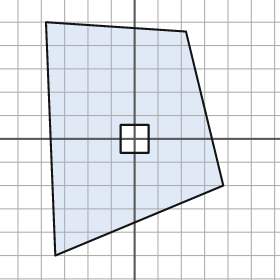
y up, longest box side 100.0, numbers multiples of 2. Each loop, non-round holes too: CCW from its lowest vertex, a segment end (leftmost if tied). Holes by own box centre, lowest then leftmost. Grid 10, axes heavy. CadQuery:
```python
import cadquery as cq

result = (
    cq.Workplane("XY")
    .moveTo(-34.0, -50.0)
    .lineTo(38.0, -20.0)
    .lineTo(22.0, 46.0)
    .lineTo(-38.0, 50.0)
    .close()
    .moveTo(-6.0, -6.0)
    .lineTo(6.0, -6.0)
    .lineTo(6.0, 6.0)
    .lineTo(-6.0, 6.0)
    .close()
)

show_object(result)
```